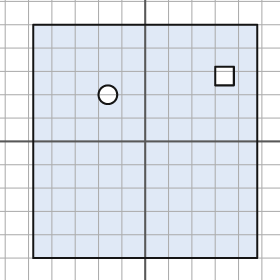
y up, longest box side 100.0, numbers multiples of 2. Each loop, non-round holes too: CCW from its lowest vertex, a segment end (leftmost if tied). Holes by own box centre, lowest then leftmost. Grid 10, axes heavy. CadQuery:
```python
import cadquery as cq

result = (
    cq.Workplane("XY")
    .moveTo(-48.0, -50.0)
    .lineTo(48.0, -50.0)
    .lineTo(48.0, 50.0)
    .lineTo(-48.0, 50.0)
    .close()
    .moveTo(-16.0, 20.0)
    .circle(4.0)
    .moveTo(30.0, 24.0)
    .lineTo(38.0, 24.0)
    .lineTo(38.0, 32.0)
    .lineTo(30.0, 32.0)
    .close()
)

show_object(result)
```